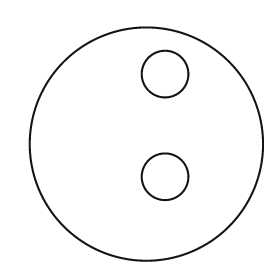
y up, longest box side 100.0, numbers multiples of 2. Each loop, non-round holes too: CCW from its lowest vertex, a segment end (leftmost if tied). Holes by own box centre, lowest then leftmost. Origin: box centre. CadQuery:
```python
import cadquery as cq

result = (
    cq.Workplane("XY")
    .moveTo(0.0, 0.0)
    .circle(50.0)
    .moveTo(8.0, -14.0)
    .circle(10.0)
    .moveTo(8.0, 30.0)
    .circle(10.0)
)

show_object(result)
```